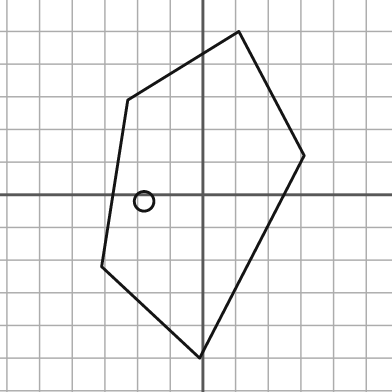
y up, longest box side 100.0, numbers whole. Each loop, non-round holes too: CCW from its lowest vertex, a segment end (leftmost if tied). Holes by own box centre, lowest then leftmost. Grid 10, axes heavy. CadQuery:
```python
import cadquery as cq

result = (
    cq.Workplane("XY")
    .moveTo(-1.0, -50.0)
    .lineTo(31.0, 12.0)
    .lineTo(11.0, 50.0)
    .lineTo(-23.0, 29.0)
    .lineTo(-31.0, -22.0)
    .close()
    .moveTo(-18.0, -2.0)
    .circle(3.0)
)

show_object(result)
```